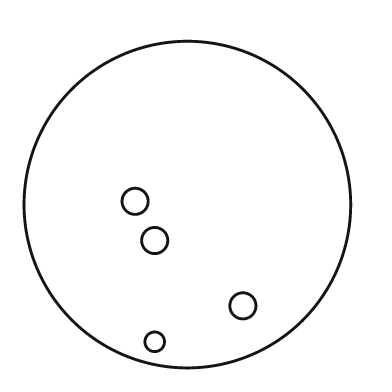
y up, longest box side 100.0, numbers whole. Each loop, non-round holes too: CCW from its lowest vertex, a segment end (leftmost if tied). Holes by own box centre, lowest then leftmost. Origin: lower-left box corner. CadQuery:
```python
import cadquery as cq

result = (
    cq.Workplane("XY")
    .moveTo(50.0, 50.0)
    .circle(50.0)
    .moveTo(40.0, 8.0)
    .circle(3.0)
    .moveTo(67.0, 19.0)
    .circle(4.0)
    .moveTo(40.0, 39.0)
    .circle(4.0)
    .moveTo(34.0, 51.0)
    .circle(4.0)
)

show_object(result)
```